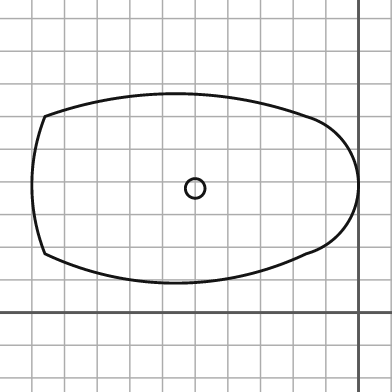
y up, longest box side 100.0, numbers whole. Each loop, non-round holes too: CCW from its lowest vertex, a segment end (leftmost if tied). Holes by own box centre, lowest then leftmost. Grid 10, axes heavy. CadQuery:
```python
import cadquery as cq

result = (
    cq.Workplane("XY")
    .moveTo(-96.0, 18.0)
    .threePointArc((-56.0, 9.0), (-16.0, 18.0))
    .threePointArc((0.0, 39.0), (-16.0, 60.0))
    .threePointArc((-56.0, 67.0), (-96.0, 60.0))
    .threePointArc((-100.0, 39.0), (-96.0, 18.0))
    .close()
    .moveTo(-50.0, 38.0)
    .circle(3.0)
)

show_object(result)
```